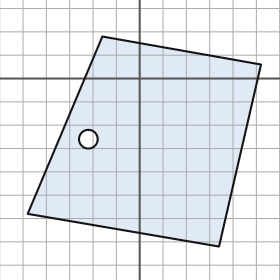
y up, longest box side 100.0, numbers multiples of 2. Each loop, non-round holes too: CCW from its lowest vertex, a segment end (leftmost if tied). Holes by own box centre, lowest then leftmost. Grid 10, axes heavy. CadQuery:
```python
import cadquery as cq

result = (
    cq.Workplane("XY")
    .moveTo(34.0, -72.0)
    .lineTo(52.0, 6.0)
    .lineTo(-16.0, 18.0)
    .lineTo(-48.0, -58.0)
    .close()
    .moveTo(-22.0, -26.0)
    .circle(4.0)
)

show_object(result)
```